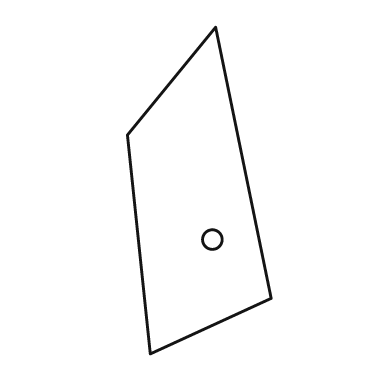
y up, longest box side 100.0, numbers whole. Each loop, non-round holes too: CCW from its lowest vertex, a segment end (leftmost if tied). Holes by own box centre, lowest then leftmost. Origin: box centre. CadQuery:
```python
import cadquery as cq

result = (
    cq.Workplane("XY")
    .moveTo(-15.0, -50.0)
    .lineTo(22.0, -33.0)
    .lineTo(5.0, 50.0)
    .lineTo(-22.0, 17.0)
    .close()
    .moveTo(4.0, -15.0)
    .circle(3.0)
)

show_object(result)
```